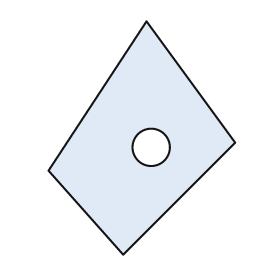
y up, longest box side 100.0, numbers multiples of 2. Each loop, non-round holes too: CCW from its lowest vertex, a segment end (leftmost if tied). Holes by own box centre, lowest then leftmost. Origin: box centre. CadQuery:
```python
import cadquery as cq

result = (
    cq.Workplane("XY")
    .moveTo(-8.0, -50.0)
    .lineTo(40.0, -2.0)
    .lineTo(2.0, 50.0)
    .lineTo(-40.0, -14.0)
    .close()
    .moveTo(4.0, -4.0)
    .circle(8.0)
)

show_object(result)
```